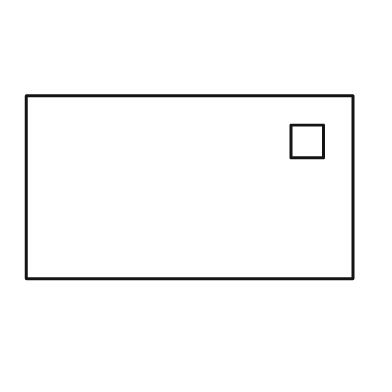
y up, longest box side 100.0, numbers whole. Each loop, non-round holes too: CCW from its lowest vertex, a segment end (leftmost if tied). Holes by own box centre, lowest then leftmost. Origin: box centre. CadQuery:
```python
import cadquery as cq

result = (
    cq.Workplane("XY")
    .moveTo(-50.0, -28.0)
    .lineTo(50.0, -28.0)
    .lineTo(50.0, 28.0)
    .lineTo(-50.0, 28.0)
    .close()
    .moveTo(31.0, 9.0)
    .lineTo(41.0, 9.0)
    .lineTo(41.0, 19.0)
    .lineTo(31.0, 19.0)
    .close()
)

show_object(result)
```